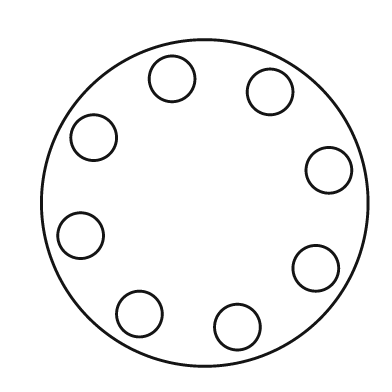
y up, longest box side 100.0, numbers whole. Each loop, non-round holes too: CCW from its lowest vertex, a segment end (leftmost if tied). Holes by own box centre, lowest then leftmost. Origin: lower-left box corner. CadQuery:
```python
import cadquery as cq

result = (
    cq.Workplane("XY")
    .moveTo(50.0, 50.0)
    .circle(50.0)
    .moveTo(60.0, 12.0)
    .circle(7.0)
    .moveTo(30.0, 16.0)
    .circle(7.0)
    .moveTo(84.0, 30.0)
    .circle(7.0)
    .moveTo(12.0, 40.0)
    .circle(7.0)
    .moveTo(88.0, 60.0)
    .circle(7.0)
    .moveTo(16.0, 70.0)
    .circle(7.0)
    .moveTo(70.0, 84.0)
    .circle(7.0)
    .moveTo(40.0, 88.0)
    .circle(7.0)
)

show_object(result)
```